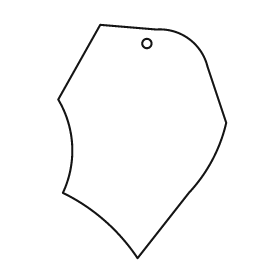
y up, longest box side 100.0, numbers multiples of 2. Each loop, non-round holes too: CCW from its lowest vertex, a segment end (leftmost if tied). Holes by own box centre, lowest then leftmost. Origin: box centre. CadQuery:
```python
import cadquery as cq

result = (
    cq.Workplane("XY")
    .moveTo(-2.0, -50.0)
    .lineTo(20.0, -22.0)
    .threePointArc((30.0, -8.0), (36.0, 8.0))
    .lineTo(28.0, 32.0)
    .threePointArc((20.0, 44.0), (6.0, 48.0))
    .lineTo(-18.0, 50.0)
    .lineTo(-36.0, 18.0)
    .threePointArc((-30.0, -2.0), (-34.0, -22.0))
    .threePointArc((-16.0, -34.0), (-2.0, -50.0))
    .close()
    .moveTo(2.0, 42.0)
    .circle(2.0)
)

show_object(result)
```